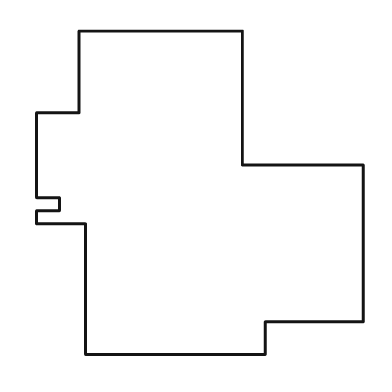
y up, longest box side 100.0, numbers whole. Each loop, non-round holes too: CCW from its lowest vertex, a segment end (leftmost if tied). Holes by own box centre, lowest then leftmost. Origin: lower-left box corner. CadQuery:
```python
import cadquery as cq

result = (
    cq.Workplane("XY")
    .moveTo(15.0, 0.0)
    .lineTo(70.0, 0.0)
    .lineTo(70.0, 10.0)
    .lineTo(100.0, 10.0)
    .lineTo(100.0, 58.0)
    .lineTo(63.0, 58.0)
    .lineTo(63.0, 99.0)
    .lineTo(13.0, 99.0)
    .lineTo(13.0, 74.0)
    .lineTo(0.0, 74.0)
    .lineTo(0.0, 48.0)
    .lineTo(7.0, 48.0)
    .lineTo(7.0, 44.0)
    .lineTo(0.0, 44.0)
    .lineTo(0.0, 40.0)
    .lineTo(15.0, 40.0)
    .close()
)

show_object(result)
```